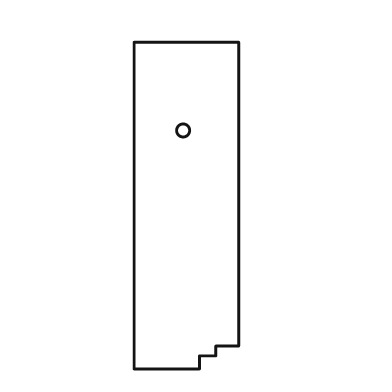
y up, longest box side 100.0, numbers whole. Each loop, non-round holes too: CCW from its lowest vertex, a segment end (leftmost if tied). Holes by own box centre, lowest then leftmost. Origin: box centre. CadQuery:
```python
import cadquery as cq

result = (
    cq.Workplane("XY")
    .moveTo(-16.0, -50.0)
    .lineTo(4.0, -50.0)
    .lineTo(4.0, -46.0)
    .lineTo(9.0, -46.0)
    .lineTo(9.0, -43.0)
    .lineTo(16.0, -43.0)
    .lineTo(16.0, 50.0)
    .lineTo(-16.0, 50.0)
    .close()
    .moveTo(-1.0, 23.0)
    .circle(2.0)
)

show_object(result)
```